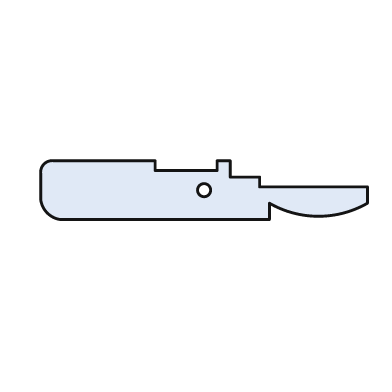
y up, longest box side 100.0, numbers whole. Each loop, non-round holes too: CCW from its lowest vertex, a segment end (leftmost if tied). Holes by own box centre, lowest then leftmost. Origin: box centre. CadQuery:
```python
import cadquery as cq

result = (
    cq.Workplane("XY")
    .moveTo(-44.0, -9.0)
    .lineTo(20.0, -9.0)
    .lineTo(20.0, -4.0)
    .threePointArc((35.0, -8.0), (50.0, -4.0))
    .lineTo(50.0, 1.0)
    .lineTo(17.0, 1.0)
    .lineTo(17.0, 4.0)
    .lineTo(8.0, 4.0)
    .lineTo(8.0, 9.0)
    .lineTo(4.0, 9.0)
    .lineTo(4.0, 6.0)
    .lineTo(-15.0, 6.0)
    .lineTo(-15.0, 9.0)
    .lineTo(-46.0, 9.0)
    .threePointArc((-49.0, 8.0), (-50.0, 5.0))
    .lineTo(-50.0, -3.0)
    .threePointArc((-48.0, -7.0), (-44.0, -9.0))
    .close()
    .moveTo(0.0, 0.0)
    .circle(2.0)
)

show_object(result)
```